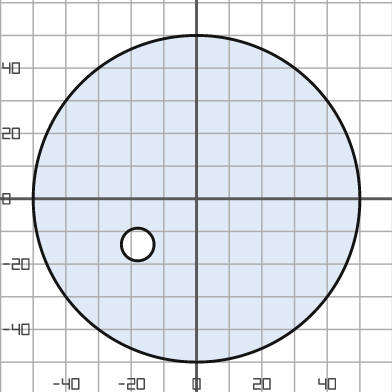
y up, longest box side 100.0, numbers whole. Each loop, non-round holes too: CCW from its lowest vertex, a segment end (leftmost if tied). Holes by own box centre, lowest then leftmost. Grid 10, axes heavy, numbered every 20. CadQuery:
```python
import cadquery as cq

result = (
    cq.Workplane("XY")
    .moveTo(0.0, 0.0)
    .circle(50.0)
    .moveTo(-18.0, -14.0)
    .circle(5.0)
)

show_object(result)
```